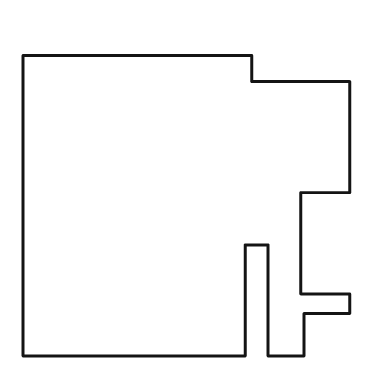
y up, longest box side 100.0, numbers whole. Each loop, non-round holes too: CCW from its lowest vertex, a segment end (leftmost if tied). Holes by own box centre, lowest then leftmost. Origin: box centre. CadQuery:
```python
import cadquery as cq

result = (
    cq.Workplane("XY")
    .moveTo(-50.0, -46.0)
    .lineTo(18.0, -46.0)
    .lineTo(18.0, -12.0)
    .lineTo(25.0, -12.0)
    .lineTo(25.0, -46.0)
    .lineTo(36.0, -46.0)
    .lineTo(36.0, -33.0)
    .lineTo(50.0, -33.0)
    .lineTo(50.0, -27.0)
    .lineTo(35.0, -27.0)
    .lineTo(35.0, 4.0)
    .lineTo(50.0, 4.0)
    .lineTo(50.0, 38.0)
    .lineTo(20.0, 38.0)
    .lineTo(20.0, 46.0)
    .lineTo(-50.0, 46.0)
    .close()
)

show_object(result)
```